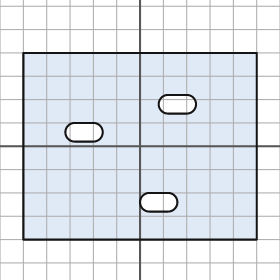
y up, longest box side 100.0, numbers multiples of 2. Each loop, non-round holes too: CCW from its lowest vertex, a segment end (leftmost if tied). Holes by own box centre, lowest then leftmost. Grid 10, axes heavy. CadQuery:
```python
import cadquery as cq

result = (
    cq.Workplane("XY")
    .moveTo(-50.0, -40.0)
    .lineTo(50.0, -40.0)
    .lineTo(50.0, 40.0)
    .lineTo(-50.0, 40.0)
    .close()
    .moveTo(4.0, -28.0)
    .lineTo(12.0, -28.0)
    .threePointArc((16.0, -24.0), (12.0, -20.0))
    .lineTo(4.0, -20.0)
    .threePointArc((0.0, -24.0), (4.0, -28.0))
    .close()
    .moveTo(-28.0, 2.0)
    .lineTo(-20.0, 2.0)
    .threePointArc((-16.0, 6.0), (-20.0, 10.0))
    .lineTo(-28.0, 10.0)
    .threePointArc((-32.0, 6.0), (-28.0, 2.0))
    .close()
    .moveTo(12.0, 14.0)
    .lineTo(20.0, 14.0)
    .threePointArc((24.0, 18.0), (20.0, 22.0))
    .lineTo(12.0, 22.0)
    .threePointArc((8.0, 18.0), (12.0, 14.0))
    .close()
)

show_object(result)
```